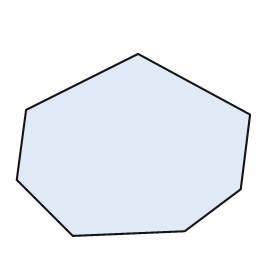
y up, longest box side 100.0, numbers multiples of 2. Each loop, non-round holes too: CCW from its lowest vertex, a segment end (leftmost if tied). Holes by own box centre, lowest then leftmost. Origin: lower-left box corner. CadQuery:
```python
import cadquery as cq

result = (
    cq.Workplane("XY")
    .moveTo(24.0, 0.0)
    .lineTo(72.0, 2.0)
    .lineTo(96.0, 20.0)
    .lineTo(100.0, 52.0)
    .lineTo(52.0, 78.0)
    .lineTo(4.0, 54.0)
    .lineTo(0.0, 24.0)
    .close()
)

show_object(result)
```